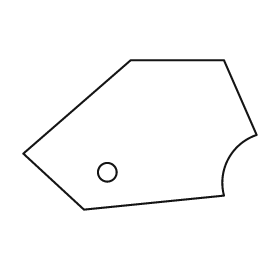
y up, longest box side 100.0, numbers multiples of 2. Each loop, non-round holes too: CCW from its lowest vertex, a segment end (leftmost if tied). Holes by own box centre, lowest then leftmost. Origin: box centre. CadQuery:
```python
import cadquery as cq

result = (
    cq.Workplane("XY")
    .moveTo(-24.0, -32.0)
    .lineTo(36.0, -26.0)
    .threePointArc((38.0, -10.0), (50.0, 0.0))
    .lineTo(36.0, 32.0)
    .lineTo(-4.0, 32.0)
    .lineTo(-50.0, -8.0)
    .close()
    .moveTo(-14.0, -16.0)
    .circle(4.0)
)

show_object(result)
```